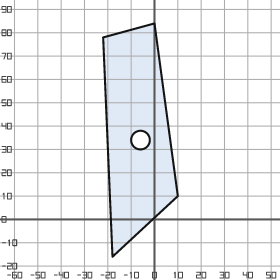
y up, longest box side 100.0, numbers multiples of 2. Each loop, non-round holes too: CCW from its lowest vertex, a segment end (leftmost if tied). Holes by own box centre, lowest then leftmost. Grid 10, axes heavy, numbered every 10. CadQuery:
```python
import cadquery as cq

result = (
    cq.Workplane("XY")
    .moveTo(-18.0, -16.0)
    .lineTo(10.0, 10.0)
    .lineTo(0.0, 84.0)
    .lineTo(-22.0, 78.0)
    .close()
    .moveTo(-6.0, 34.0)
    .circle(4.0)
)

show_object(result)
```